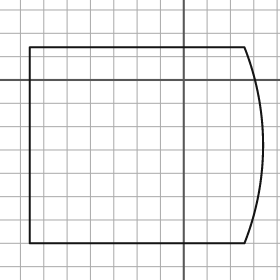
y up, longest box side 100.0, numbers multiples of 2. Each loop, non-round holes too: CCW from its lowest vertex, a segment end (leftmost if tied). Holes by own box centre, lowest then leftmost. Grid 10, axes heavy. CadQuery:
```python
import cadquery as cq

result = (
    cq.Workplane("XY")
    .moveTo(-66.0, -70.0)
    .lineTo(26.0, -70.0)
    .threePointArc((34.0, -28.0), (26.0, 14.0))
    .lineTo(-66.0, 14.0)
    .close()
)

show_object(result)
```